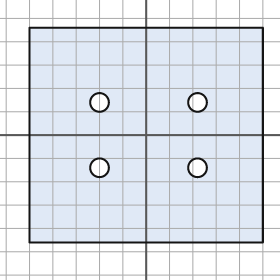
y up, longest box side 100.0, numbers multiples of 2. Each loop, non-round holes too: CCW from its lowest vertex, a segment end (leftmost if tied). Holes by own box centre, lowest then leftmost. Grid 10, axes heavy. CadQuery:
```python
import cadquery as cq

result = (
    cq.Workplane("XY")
    .moveTo(-50.0, -46.0)
    .lineTo(50.0, -46.0)
    .lineTo(50.0, 46.0)
    .lineTo(-50.0, 46.0)
    .close()
    .moveTo(-20.0, -14.0)
    .circle(4.0)
    .moveTo(22.0, -14.0)
    .circle(4.0)
    .moveTo(-20.0, 14.0)
    .circle(4.0)
    .moveTo(22.0, 14.0)
    .circle(4.0)
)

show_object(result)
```